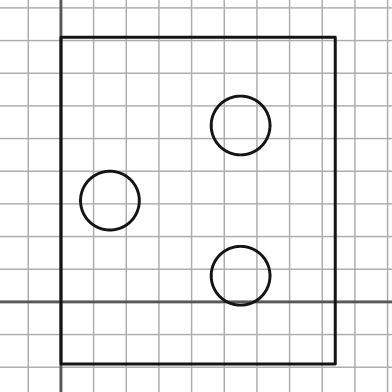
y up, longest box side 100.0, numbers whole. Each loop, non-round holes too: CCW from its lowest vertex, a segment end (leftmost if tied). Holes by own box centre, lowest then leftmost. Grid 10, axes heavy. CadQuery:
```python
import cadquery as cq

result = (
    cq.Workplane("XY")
    .moveTo(0.0, -19.0)
    .lineTo(84.0, -19.0)
    .lineTo(84.0, 81.0)
    .lineTo(0.0, 81.0)
    .close()
    .moveTo(55.0, 8.0)
    .circle(9.0)
    .moveTo(15.0, 31.0)
    .circle(9.0)
    .moveTo(55.0, 54.0)
    .circle(9.0)
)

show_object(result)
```